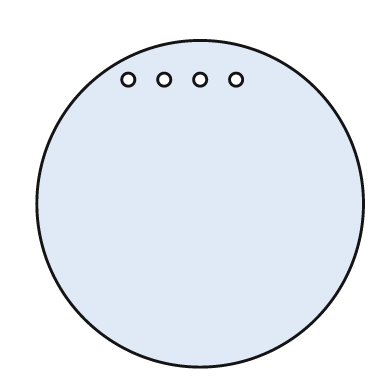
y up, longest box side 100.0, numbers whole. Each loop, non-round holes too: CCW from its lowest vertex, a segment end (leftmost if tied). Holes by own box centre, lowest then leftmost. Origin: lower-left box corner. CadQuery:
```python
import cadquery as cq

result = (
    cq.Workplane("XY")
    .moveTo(50.0, 50.0)
    .circle(50.0)
    .moveTo(28.0, 88.0)
    .circle(2.0)
    .moveTo(39.0, 88.0)
    .circle(2.0)
    .moveTo(50.0, 88.0)
    .circle(2.0)
    .moveTo(61.0, 88.0)
    .circle(2.0)
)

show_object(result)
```